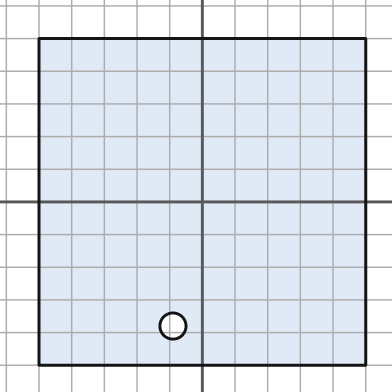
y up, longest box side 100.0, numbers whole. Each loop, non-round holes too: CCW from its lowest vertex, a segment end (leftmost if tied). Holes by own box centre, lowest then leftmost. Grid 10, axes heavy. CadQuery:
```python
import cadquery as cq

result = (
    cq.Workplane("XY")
    .moveTo(-50.0, -50.0)
    .lineTo(50.0, -50.0)
    .lineTo(50.0, 50.0)
    .lineTo(-50.0, 50.0)
    .close()
    .moveTo(-9.0, -38.0)
    .circle(4.0)
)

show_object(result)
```